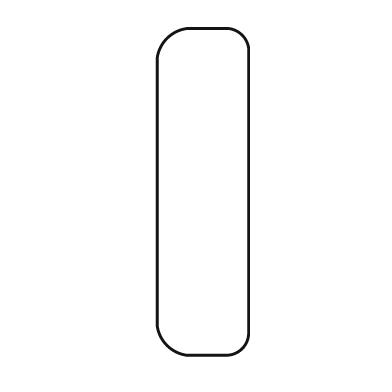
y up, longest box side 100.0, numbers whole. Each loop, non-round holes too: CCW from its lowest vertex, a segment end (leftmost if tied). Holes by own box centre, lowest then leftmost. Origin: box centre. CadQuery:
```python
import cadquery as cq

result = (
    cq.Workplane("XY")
    .moveTo(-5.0, -50.0)
    .lineTo(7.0, -50.0)
    .threePointArc((12.0, -48.0), (14.0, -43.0))
    .lineTo(14.0, 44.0)
    .threePointArc((12.0, 48.0), (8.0, 50.0))
    .lineTo(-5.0, 50.0)
    .threePointArc((-11.0, 47.0), (-14.0, 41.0))
    .lineTo(-14.0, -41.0)
    .threePointArc((-11.0, -47.0), (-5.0, -50.0))
    .close()
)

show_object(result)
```